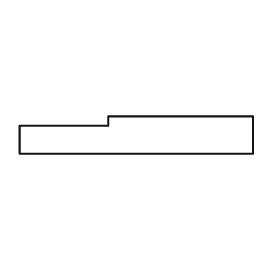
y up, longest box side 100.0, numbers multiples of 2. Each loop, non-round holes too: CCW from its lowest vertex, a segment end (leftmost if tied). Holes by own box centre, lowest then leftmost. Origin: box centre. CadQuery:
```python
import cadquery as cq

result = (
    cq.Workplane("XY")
    .moveTo(-50.0, -8.0)
    .lineTo(50.0, -8.0)
    .lineTo(50.0, 8.0)
    .lineTo(-12.0, 8.0)
    .lineTo(-12.0, 4.0)
    .lineTo(-50.0, 4.0)
    .close()
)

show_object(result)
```